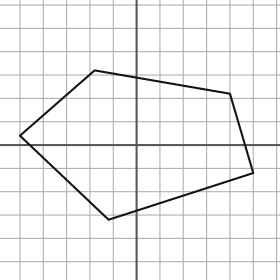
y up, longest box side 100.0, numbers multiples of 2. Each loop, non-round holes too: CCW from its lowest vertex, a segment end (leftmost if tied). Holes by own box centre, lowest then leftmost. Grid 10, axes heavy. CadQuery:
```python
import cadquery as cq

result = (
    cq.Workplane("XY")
    .moveTo(-12.0, -32.0)
    .lineTo(50.0, -12.0)
    .lineTo(40.0, 22.0)
    .lineTo(-18.0, 32.0)
    .lineTo(-50.0, 4.0)
    .close()
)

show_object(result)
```